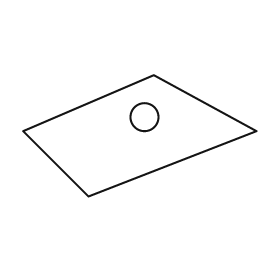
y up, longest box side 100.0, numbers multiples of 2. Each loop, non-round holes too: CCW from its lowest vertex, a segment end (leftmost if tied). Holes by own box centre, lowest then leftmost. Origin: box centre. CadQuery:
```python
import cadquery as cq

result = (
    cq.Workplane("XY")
    .moveTo(-22.0, -26.0)
    .lineTo(50.0, 2.0)
    .lineTo(6.0, 26.0)
    .lineTo(-50.0, 2.0)
    .close()
    .moveTo(2.0, 8.0)
    .circle(6.0)
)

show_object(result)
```